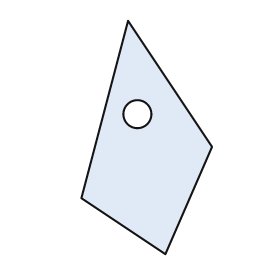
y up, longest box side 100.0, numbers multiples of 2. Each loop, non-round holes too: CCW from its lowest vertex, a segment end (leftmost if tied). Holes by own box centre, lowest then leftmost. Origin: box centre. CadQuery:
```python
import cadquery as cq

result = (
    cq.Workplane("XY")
    .moveTo(8.0, -50.0)
    .lineTo(28.0, -4.0)
    .lineTo(-8.0, 50.0)
    .lineTo(-28.0, -26.0)
    .close()
    .moveTo(-4.0, 10.0)
    .circle(6.0)
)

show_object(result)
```